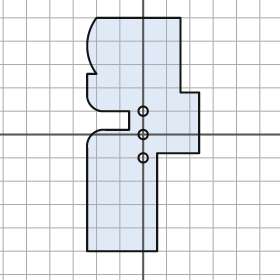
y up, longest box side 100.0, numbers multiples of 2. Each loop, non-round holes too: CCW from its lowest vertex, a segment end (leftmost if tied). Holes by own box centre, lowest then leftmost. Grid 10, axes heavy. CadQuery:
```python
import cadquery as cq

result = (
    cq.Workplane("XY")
    .moveTo(-24.0, -50.0)
    .lineTo(6.0, -50.0)
    .lineTo(6.0, -8.0)
    .lineTo(24.0, -8.0)
    .lineTo(24.0, 18.0)
    .lineTo(16.0, 18.0)
    .lineTo(16.0, 50.0)
    .lineTo(-20.0, 50.0)
    .threePointArc((-24.0, 38.0), (-20.0, 26.0))
    .lineTo(-24.0, 26.0)
    .lineTo(-24.0, 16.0)
    .threePointArc((-22.0, 12.0), (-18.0, 10.0))
    .lineTo(-6.0, 10.0)
    .lineTo(-6.0, 2.0)
    .lineTo(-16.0, 2.0)
    .threePointArc((-22.0, 0.0), (-24.0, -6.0))
    .close()
    .moveTo(0.0, -10.0)
    .circle(2.0)
    .moveTo(0.0, 0.0)
    .circle(2.0)
    .moveTo(0.0, 10.0)
    .circle(2.0)
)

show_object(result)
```